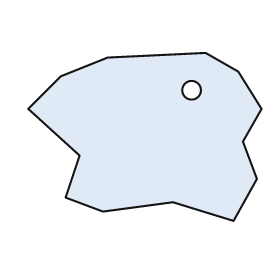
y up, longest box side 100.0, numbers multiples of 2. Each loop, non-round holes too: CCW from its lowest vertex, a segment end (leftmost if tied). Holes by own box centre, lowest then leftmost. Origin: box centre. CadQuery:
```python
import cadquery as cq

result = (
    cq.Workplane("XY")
    .moveTo(38.0, -36.0)
    .lineTo(48.0, -18.0)
    .lineTo(42.0, -2.0)
    .lineTo(50.0, 12.0)
    .lineTo(40.0, 28.0)
    .lineTo(26.0, 36.0)
    .lineTo(-16.0, 34.0)
    .lineTo(-36.0, 26.0)
    .lineTo(-50.0, 12.0)
    .lineTo(-28.0, -8.0)
    .lineTo(-34.0, -26.0)
    .lineTo(-18.0, -32.0)
    .lineTo(12.0, -28.0)
    .close()
    .moveTo(20.0, 20.0)
    .circle(4.0)
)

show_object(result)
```